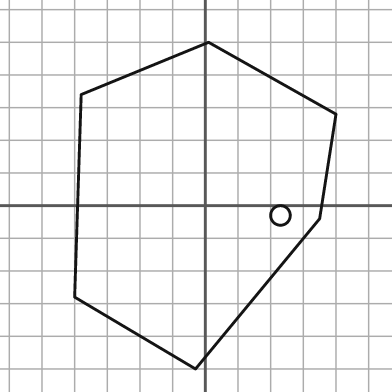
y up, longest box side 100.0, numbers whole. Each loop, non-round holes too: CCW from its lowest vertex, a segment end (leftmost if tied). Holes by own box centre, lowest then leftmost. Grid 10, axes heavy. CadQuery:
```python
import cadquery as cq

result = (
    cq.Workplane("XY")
    .moveTo(-3.0, -50.0)
    .lineTo(35.0, -4.0)
    .lineTo(40.0, 28.0)
    .lineTo(1.0, 50.0)
    .lineTo(-38.0, 34.0)
    .lineTo(-40.0, -28.0)
    .close()
    .moveTo(23.0, -3.0)
    .circle(3.0)
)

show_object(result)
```